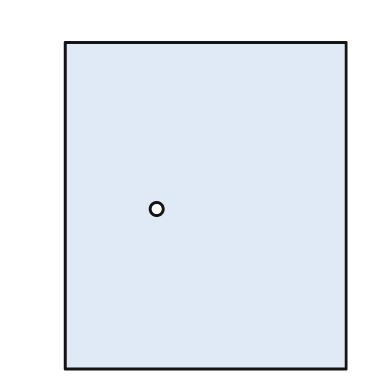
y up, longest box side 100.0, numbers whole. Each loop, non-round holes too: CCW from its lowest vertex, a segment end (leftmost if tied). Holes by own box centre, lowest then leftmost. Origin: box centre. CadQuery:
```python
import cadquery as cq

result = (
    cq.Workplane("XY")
    .moveTo(-43.0, -50.0)
    .lineTo(43.0, -50.0)
    .lineTo(43.0, 50.0)
    .lineTo(-43.0, 50.0)
    .close()
    .moveTo(-15.0, -1.0)
    .circle(2.0)
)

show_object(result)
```